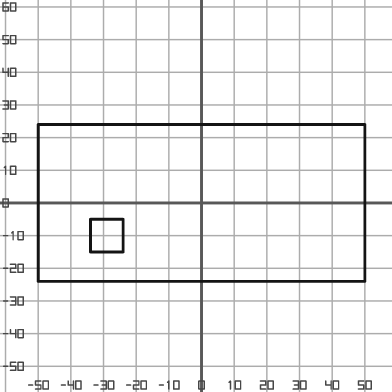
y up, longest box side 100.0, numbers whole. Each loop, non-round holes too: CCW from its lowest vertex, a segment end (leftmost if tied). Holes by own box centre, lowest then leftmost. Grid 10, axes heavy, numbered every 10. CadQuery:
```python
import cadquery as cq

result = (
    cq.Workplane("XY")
    .moveTo(-50.0, -24.0)
    .lineTo(50.0, -24.0)
    .lineTo(50.0, 24.0)
    .lineTo(-50.0, 24.0)
    .close()
    .moveTo(-34.0, -15.0)
    .lineTo(-24.0, -15.0)
    .lineTo(-24.0, -5.0)
    .lineTo(-34.0, -5.0)
    .close()
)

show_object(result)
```